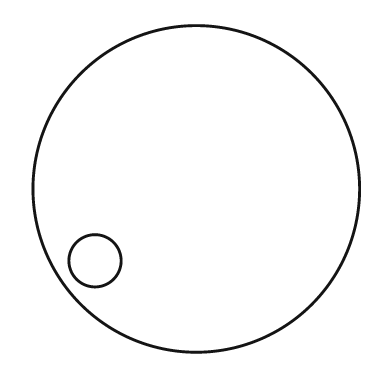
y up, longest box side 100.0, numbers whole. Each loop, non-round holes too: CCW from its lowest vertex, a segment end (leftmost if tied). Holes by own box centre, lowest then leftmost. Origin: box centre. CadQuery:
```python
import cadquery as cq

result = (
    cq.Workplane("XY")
    .moveTo(0.0, 0.0)
    .circle(50.0)
    .moveTo(-31.0, -22.0)
    .circle(8.0)
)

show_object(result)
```